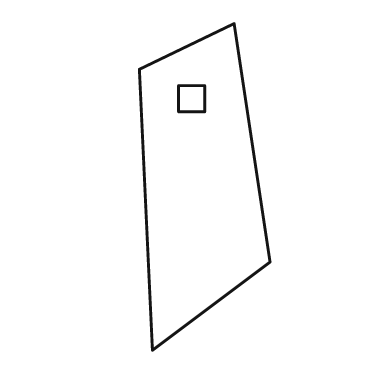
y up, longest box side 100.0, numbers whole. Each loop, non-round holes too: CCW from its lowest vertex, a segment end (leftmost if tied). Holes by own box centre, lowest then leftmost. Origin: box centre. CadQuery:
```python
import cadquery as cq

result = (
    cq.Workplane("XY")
    .moveTo(-16.0, -50.0)
    .lineTo(20.0, -23.0)
    .lineTo(9.0, 50.0)
    .lineTo(-20.0, 36.0)
    .close()
    .moveTo(-8.0, 23.0)
    .lineTo(0.0, 23.0)
    .lineTo(0.0, 31.0)
    .lineTo(-8.0, 31.0)
    .close()
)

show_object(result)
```